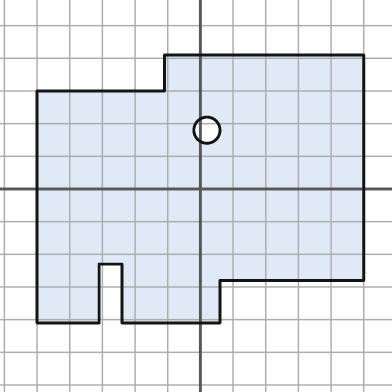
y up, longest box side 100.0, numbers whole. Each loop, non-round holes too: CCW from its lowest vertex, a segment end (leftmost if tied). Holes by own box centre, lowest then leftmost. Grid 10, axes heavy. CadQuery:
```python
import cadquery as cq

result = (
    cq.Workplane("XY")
    .moveTo(-50.0, -41.0)
    .lineTo(-31.0, -41.0)
    .lineTo(-31.0, -23.0)
    .lineTo(-24.0, -23.0)
    .lineTo(-24.0, -41.0)
    .lineTo(6.0, -41.0)
    .lineTo(6.0, -28.0)
    .lineTo(50.0, -28.0)
    .lineTo(50.0, 41.0)
    .lineTo(-11.0, 41.0)
    .lineTo(-11.0, 30.0)
    .lineTo(-50.0, 30.0)
    .close()
    .moveTo(2.0, 18.0)
    .circle(4.0)
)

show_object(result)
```